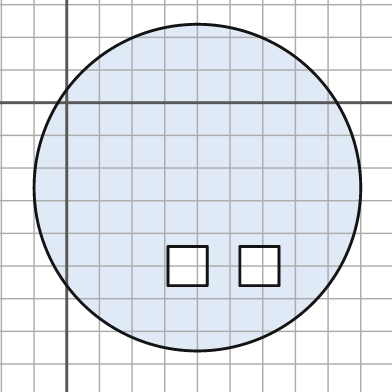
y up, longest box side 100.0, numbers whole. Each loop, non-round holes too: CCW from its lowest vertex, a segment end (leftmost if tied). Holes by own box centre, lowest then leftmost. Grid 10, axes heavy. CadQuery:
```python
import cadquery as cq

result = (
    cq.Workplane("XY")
    .moveTo(40.0, -26.0)
    .circle(50.0)
    .moveTo(31.0, -56.0)
    .lineTo(43.0, -56.0)
    .lineTo(43.0, -44.0)
    .lineTo(31.0, -44.0)
    .close()
    .moveTo(53.0, -56.0)
    .lineTo(65.0, -56.0)
    .lineTo(65.0, -44.0)
    .lineTo(53.0, -44.0)
    .close()
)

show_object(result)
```